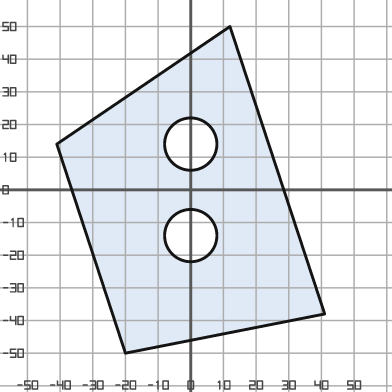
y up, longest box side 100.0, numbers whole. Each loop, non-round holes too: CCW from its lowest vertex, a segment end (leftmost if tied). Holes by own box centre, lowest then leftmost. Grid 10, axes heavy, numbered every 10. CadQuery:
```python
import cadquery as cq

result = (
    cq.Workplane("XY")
    .moveTo(-20.0, -50.0)
    .lineTo(41.0, -38.0)
    .lineTo(12.0, 50.0)
    .lineTo(-41.0, 14.0)
    .close()
    .moveTo(0.0, -14.0)
    .circle(8.0)
    .moveTo(0.0, 14.0)
    .circle(8.0)
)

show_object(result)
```